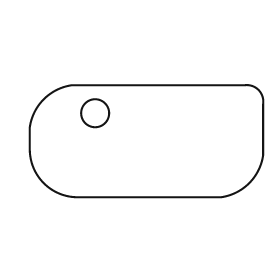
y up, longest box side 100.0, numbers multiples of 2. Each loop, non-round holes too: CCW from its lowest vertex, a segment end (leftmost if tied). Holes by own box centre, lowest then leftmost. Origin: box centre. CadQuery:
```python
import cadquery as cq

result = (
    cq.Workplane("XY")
    .moveTo(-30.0, -24.0)
    .lineTo(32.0, -24.0)
    .threePointArc((44.0, -18.0), (50.0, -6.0))
    .lineTo(50.0, 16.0)
    .threePointArc((48.0, 22.0), (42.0, 24.0))
    .lineTo(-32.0, 24.0)
    .threePointArc((-44.0, 18.0), (-50.0, 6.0))
    .lineTo(-50.0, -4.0)
    .threePointArc((-44.0, -18.0), (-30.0, -24.0))
    .close()
    .moveTo(-22.0, 12.0)
    .circle(6.0)
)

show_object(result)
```